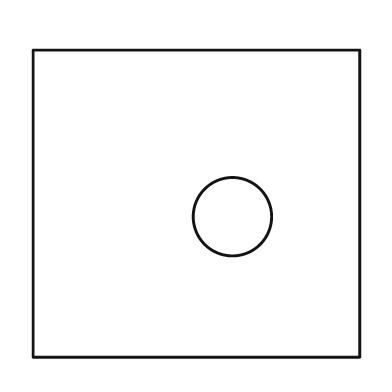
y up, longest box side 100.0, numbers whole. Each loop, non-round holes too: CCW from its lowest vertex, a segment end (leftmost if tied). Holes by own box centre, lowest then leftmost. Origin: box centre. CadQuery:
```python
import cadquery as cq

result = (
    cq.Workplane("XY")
    .moveTo(-50.0, -47.0)
    .lineTo(50.0, -47.0)
    .lineTo(50.0, 47.0)
    .lineTo(-50.0, 47.0)
    .close()
    .moveTo(11.0, -4.0)
    .circle(12.0)
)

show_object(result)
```